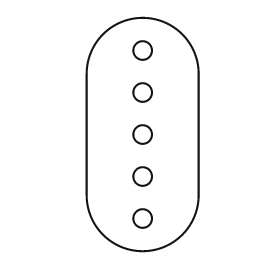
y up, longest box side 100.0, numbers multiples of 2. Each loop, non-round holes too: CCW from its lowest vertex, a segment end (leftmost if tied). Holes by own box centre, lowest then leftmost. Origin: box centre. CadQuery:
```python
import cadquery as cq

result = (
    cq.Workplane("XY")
    .moveTo(-24.0, -26.0)
    .threePointArc((0.0, -50.0), (24.0, -26.0))
    .lineTo(24.0, 26.0)
    .threePointArc((0.0, 50.0), (-24.0, 26.0))
    .close()
    .moveTo(0.0, -36.0)
    .circle(4.0)
    .moveTo(0.0, -18.0)
    .circle(4.0)
    .moveTo(0.0, 0.0)
    .circle(4.0)
    .moveTo(0.0, 18.0)
    .circle(4.0)
    .moveTo(0.0, 36.0)
    .circle(4.0)
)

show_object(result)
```